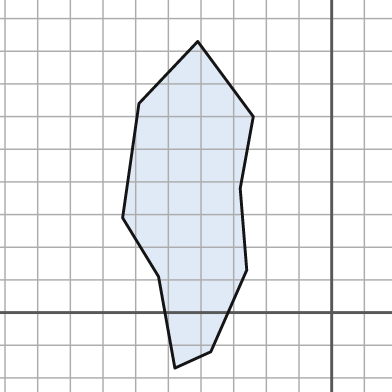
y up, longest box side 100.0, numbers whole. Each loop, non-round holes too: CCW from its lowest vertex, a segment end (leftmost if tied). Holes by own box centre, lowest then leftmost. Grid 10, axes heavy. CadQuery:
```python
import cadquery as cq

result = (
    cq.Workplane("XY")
    .moveTo(-48.0, -17.0)
    .lineTo(-37.0, -12.0)
    .lineTo(-26.0, 13.0)
    .lineTo(-28.0, 38.0)
    .lineTo(-24.0, 60.0)
    .lineTo(-41.0, 83.0)
    .lineTo(-59.0, 64.0)
    .lineTo(-64.0, 29.0)
    .lineTo(-53.0, 11.0)
    .close()
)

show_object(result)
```